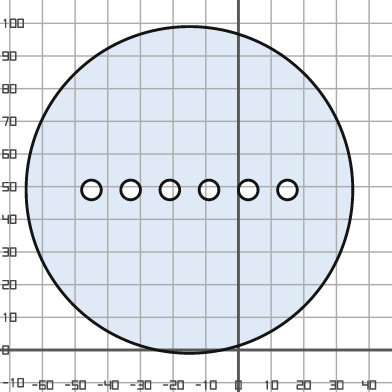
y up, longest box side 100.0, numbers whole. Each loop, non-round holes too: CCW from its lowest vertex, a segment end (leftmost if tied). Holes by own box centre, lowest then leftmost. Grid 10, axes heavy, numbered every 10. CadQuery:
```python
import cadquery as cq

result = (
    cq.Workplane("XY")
    .moveTo(-15.0, 49.0)
    .circle(50.0)
    .moveTo(-45.0, 49.0)
    .circle(3.0)
    .moveTo(-33.0, 49.0)
    .circle(3.0)
    .moveTo(-21.0, 49.0)
    .circle(3.0)
    .moveTo(-9.0, 49.0)
    .circle(3.0)
    .moveTo(3.0, 49.0)
    .circle(3.0)
    .moveTo(15.0, 49.0)
    .circle(3.0)
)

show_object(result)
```